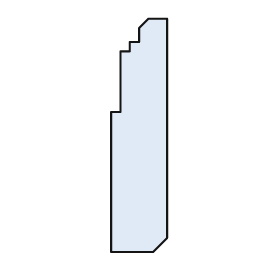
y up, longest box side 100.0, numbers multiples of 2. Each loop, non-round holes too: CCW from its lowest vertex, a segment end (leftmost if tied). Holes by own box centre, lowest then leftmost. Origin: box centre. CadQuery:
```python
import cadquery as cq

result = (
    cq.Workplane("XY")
    .moveTo(-12.0, -50.0)
    .lineTo(6.0, -50.0)
    .lineTo(12.0, -44.0)
    .lineTo(12.0, 50.0)
    .lineTo(4.0, 50.0)
    .lineTo(0.0, 46.0)
    .lineTo(0.0, 40.0)
    .lineTo(-4.0, 40.0)
    .lineTo(-4.0, 36.0)
    .lineTo(-8.0, 36.0)
    .lineTo(-8.0, 10.0)
    .lineTo(-12.0, 10.0)
    .close()
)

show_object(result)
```